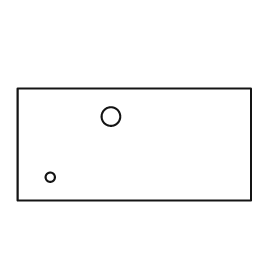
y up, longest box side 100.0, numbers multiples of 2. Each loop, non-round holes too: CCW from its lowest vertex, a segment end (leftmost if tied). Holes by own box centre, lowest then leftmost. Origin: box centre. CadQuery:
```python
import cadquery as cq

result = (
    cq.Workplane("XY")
    .moveTo(-50.0, -24.0)
    .lineTo(50.0, -24.0)
    .lineTo(50.0, 24.0)
    .lineTo(-50.0, 24.0)
    .close()
    .moveTo(-36.0, -14.0)
    .circle(2.0)
    .moveTo(-10.0, 12.0)
    .circle(4.0)
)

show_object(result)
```